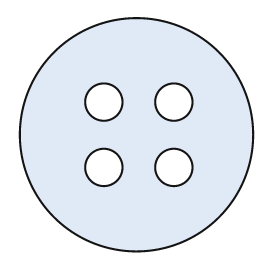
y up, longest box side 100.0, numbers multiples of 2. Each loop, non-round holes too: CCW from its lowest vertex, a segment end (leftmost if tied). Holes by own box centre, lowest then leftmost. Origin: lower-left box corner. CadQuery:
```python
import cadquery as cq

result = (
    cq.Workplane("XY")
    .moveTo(50.0, 50.0)
    .circle(50.0)
    .moveTo(36.0, 36.0)
    .circle(8.0)
    .moveTo(66.0, 36.0)
    .circle(8.0)
    .moveTo(36.0, 64.0)
    .circle(8.0)
    .moveTo(66.0, 64.0)
    .circle(8.0)
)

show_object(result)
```